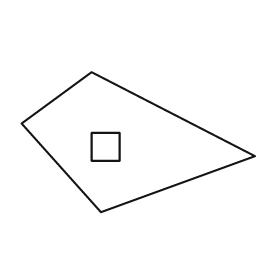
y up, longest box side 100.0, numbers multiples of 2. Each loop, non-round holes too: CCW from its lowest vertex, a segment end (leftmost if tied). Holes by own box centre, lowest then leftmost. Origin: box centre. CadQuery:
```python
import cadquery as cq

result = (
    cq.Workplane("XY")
    .moveTo(-16.0, -30.0)
    .lineTo(50.0, -6.0)
    .lineTo(-20.0, 30.0)
    .lineTo(-50.0, 8.0)
    .close()
    .moveTo(-20.0, -8.0)
    .lineTo(-8.0, -8.0)
    .lineTo(-8.0, 4.0)
    .lineTo(-20.0, 4.0)
    .close()
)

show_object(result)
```